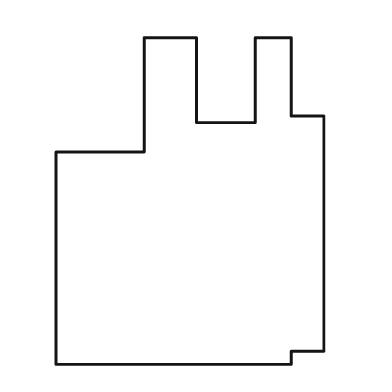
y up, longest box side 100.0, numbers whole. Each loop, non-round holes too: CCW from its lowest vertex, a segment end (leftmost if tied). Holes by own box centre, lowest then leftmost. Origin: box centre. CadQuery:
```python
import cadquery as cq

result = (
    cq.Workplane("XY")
    .moveTo(-41.0, -50.0)
    .lineTo(31.0, -50.0)
    .lineTo(31.0, -46.0)
    .lineTo(41.0, -46.0)
    .lineTo(41.0, 26.0)
    .lineTo(31.0, 26.0)
    .lineTo(31.0, 50.0)
    .lineTo(20.0, 50.0)
    .lineTo(20.0, 24.0)
    .lineTo(2.0, 24.0)
    .lineTo(2.0, 50.0)
    .lineTo(-14.0, 50.0)
    .lineTo(-14.0, 15.0)
    .lineTo(-41.0, 15.0)
    .close()
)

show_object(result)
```